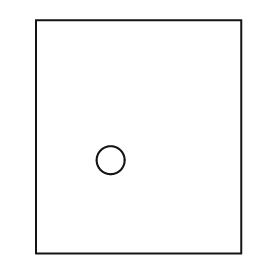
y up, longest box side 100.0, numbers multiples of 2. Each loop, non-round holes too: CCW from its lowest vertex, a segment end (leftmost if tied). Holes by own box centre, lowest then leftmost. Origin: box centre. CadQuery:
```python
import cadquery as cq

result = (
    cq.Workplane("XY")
    .moveTo(-44.0, -50.0)
    .lineTo(44.0, -50.0)
    .lineTo(44.0, 50.0)
    .lineTo(-44.0, 50.0)
    .close()
    .moveTo(-12.0, -10.0)
    .circle(6.0)
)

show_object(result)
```